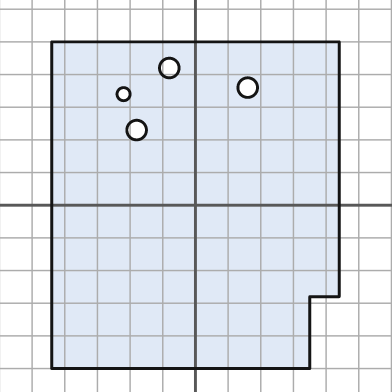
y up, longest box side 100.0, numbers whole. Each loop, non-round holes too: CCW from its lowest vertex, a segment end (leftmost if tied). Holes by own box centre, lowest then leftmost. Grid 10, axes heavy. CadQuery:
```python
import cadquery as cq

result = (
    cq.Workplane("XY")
    .moveTo(-44.0, -50.0)
    .lineTo(35.0, -50.0)
    .lineTo(35.0, -28.0)
    .lineTo(44.0, -28.0)
    .lineTo(44.0, 50.0)
    .lineTo(-44.0, 50.0)
    .close()
    .moveTo(-18.0, 23.0)
    .circle(3.0)
    .moveTo(-22.0, 34.0)
    .circle(2.0)
    .moveTo(16.0, 36.0)
    .circle(3.0)
    .moveTo(-8.0, 42.0)
    .circle(3.0)
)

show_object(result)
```